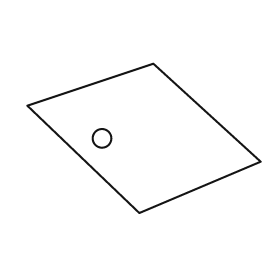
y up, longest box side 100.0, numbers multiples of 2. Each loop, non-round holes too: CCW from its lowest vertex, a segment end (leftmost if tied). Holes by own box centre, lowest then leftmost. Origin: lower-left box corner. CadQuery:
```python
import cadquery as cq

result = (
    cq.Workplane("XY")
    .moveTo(48.0, 0.0)
    .lineTo(100.0, 22.0)
    .lineTo(54.0, 64.0)
    .lineTo(0.0, 46.0)
    .close()
    .moveTo(32.0, 32.0)
    .circle(4.0)
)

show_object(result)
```